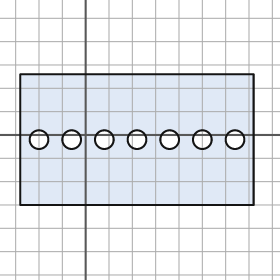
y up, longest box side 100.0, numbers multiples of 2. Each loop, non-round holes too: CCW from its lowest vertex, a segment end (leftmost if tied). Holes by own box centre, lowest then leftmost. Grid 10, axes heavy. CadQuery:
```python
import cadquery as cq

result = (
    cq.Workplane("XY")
    .moveTo(-28.0, -30.0)
    .lineTo(72.0, -30.0)
    .lineTo(72.0, 26.0)
    .lineTo(-28.0, 26.0)
    .close()
    .moveTo(-20.0, -2.0)
    .circle(4.0)
    .moveTo(-6.0, -2.0)
    .circle(4.0)
    .moveTo(8.0, -2.0)
    .circle(4.0)
    .moveTo(22.0, -2.0)
    .circle(4.0)
    .moveTo(36.0, -2.0)
    .circle(4.0)
    .moveTo(50.0, -2.0)
    .circle(4.0)
    .moveTo(64.0, -2.0)
    .circle(4.0)
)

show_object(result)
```